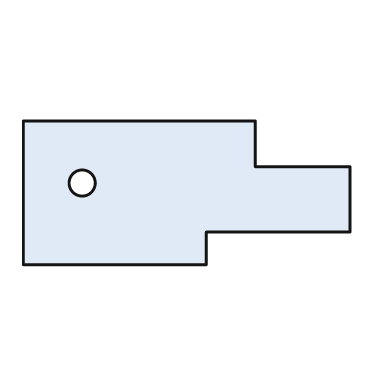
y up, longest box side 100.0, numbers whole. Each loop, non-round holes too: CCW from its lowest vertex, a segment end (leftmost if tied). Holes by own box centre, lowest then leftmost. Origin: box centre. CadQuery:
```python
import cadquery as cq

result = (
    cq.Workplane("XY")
    .moveTo(-50.0, -22.0)
    .lineTo(6.0, -22.0)
    .lineTo(6.0, -12.0)
    .lineTo(50.0, -12.0)
    .lineTo(50.0, 8.0)
    .lineTo(21.0, 8.0)
    .lineTo(21.0, 22.0)
    .lineTo(-50.0, 22.0)
    .close()
    .moveTo(-32.0, 3.0)
    .circle(4.0)
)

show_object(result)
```